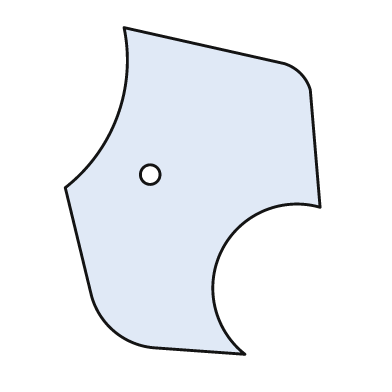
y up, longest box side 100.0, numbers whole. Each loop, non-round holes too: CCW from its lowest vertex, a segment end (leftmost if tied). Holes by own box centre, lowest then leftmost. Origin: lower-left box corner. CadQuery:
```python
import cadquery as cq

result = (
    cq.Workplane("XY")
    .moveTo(55.0, 0.0)
    .threePointArc((48.0, 32.0), (78.0, 45.0))
    .lineTo(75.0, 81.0)
    .threePointArc((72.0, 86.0), (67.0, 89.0))
    .lineTo(18.0, 100.0)
    .threePointArc((16.0, 73.0), (0.0, 51.0))
    .lineTo(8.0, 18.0)
    .threePointArc((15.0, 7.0), (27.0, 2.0))
    .close()
    .moveTo(26.0, 55.0)
    .circle(3.0)
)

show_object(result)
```